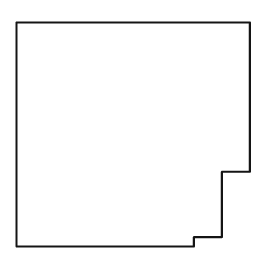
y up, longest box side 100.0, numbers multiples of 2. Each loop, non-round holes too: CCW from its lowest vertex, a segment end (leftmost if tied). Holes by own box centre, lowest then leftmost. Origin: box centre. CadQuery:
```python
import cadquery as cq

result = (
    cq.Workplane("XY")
    .moveTo(-50.0, -48.0)
    .lineTo(26.0, -48.0)
    .lineTo(26.0, -44.0)
    .lineTo(38.0, -44.0)
    .lineTo(38.0, -16.0)
    .lineTo(50.0, -16.0)
    .lineTo(50.0, 48.0)
    .lineTo(-50.0, 48.0)
    .close()
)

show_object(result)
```